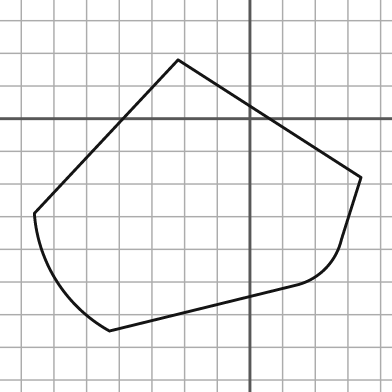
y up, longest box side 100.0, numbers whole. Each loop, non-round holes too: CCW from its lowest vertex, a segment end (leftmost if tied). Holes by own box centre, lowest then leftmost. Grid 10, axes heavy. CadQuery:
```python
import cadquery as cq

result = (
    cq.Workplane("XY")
    .moveTo(-43.0, -65.0)
    .lineTo(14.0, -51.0)
    .threePointArc((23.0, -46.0), (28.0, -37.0))
    .lineTo(34.0, -18.0)
    .lineTo(-22.0, 18.0)
    .lineTo(-66.0, -29.0)
    .threePointArc((-59.0, -50.0), (-43.0, -65.0))
    .close()
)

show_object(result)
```